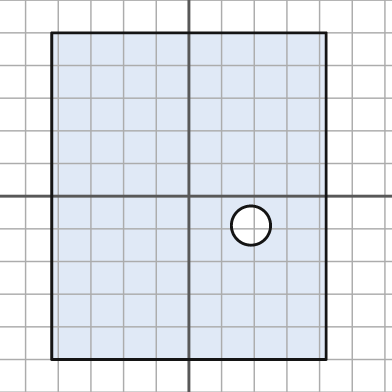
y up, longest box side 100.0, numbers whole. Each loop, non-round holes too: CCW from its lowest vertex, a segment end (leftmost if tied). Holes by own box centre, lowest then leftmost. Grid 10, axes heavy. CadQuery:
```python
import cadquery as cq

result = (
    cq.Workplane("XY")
    .moveTo(-42.0, -50.0)
    .lineTo(42.0, -50.0)
    .lineTo(42.0, 50.0)
    .lineTo(-42.0, 50.0)
    .close()
    .moveTo(19.0, -9.0)
    .circle(6.0)
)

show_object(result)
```